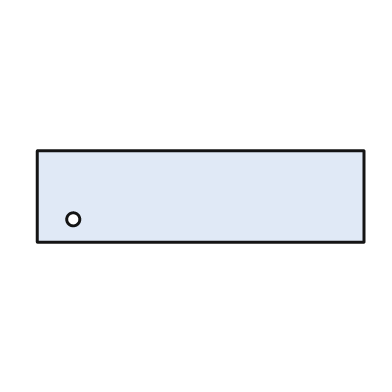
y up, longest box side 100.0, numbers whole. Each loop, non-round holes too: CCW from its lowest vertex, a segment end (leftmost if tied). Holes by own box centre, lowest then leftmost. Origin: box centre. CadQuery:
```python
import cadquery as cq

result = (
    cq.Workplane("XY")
    .moveTo(-50.0, -14.0)
    .lineTo(50.0, -14.0)
    .lineTo(50.0, 14.0)
    .lineTo(-50.0, 14.0)
    .close()
    .moveTo(-39.0, -7.0)
    .circle(2.0)
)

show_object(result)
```